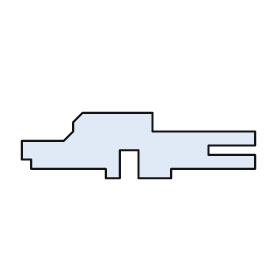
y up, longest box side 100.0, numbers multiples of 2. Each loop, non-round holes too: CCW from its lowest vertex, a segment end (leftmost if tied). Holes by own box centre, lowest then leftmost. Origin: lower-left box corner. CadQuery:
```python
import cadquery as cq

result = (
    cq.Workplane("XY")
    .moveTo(36.0, 0.0)
    .lineTo(42.0, 0.0)
    .lineTo(42.0, 12.0)
    .lineTo(50.0, 12.0)
    .lineTo(50.0, 0.0)
    .lineTo(64.0, 0.0)
    .lineTo(64.0, 4.0)
    .lineTo(100.0, 4.0)
    .lineTo(100.0, 10.0)
    .lineTo(80.0, 10.0)
    .lineTo(80.0, 14.0)
    .lineTo(100.0, 14.0)
    .lineTo(100.0, 20.0)
    .lineTo(56.0, 20.0)
    .lineTo(56.0, 28.0)
    .lineTo(26.0, 28.0)
    .lineTo(22.0, 24.0)
    .lineTo(22.0, 20.0)
    .lineTo(18.0, 16.0)
    .lineTo(0.0, 16.0)
    .lineTo(0.0, 8.0)
    .lineTo(4.0, 8.0)
    .lineTo(4.0, 4.0)
    .lineTo(36.0, 4.0)
    .close()
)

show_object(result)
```